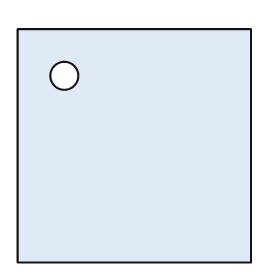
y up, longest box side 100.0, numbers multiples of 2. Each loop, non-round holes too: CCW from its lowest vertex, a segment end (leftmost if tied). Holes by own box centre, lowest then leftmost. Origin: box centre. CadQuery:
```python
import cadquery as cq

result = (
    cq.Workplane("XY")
    .moveTo(-50.0, -50.0)
    .lineTo(50.0, -50.0)
    .lineTo(50.0, 50.0)
    .lineTo(-50.0, 50.0)
    .close()
    .moveTo(-30.0, 30.0)
    .circle(6.0)
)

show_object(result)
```